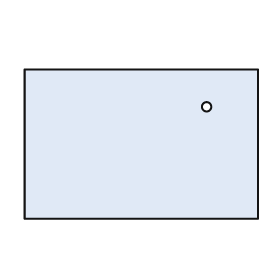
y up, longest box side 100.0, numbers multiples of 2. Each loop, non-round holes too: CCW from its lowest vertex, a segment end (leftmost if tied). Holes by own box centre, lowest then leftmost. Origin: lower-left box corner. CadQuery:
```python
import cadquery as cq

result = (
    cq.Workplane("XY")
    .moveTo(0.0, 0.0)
    .lineTo(100.0, 0.0)
    .lineTo(100.0, 64.0)
    .lineTo(0.0, 64.0)
    .close()
    .moveTo(78.0, 48.0)
    .circle(2.0)
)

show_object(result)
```